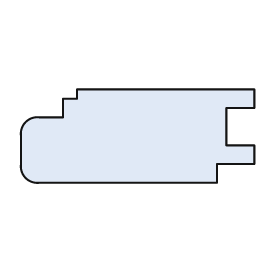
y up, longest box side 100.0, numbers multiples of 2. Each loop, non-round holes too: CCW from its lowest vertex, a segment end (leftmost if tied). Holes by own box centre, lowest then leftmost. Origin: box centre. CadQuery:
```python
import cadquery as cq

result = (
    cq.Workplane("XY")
    .moveTo(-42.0, -20.0)
    .lineTo(34.0, -20.0)
    .lineTo(34.0, -12.0)
    .lineTo(50.0, -12.0)
    .lineTo(50.0, -4.0)
    .lineTo(38.0, -4.0)
    .lineTo(38.0, 12.0)
    .lineTo(50.0, 12.0)
    .lineTo(50.0, 20.0)
    .lineTo(-26.0, 20.0)
    .lineTo(-26.0, 16.0)
    .lineTo(-32.0, 16.0)
    .lineTo(-32.0, 8.0)
    .lineTo(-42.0, 8.0)
    .threePointArc((-48.0, 6.0), (-50.0, 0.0))
    .lineTo(-50.0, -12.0)
    .threePointArc((-48.0, -18.0), (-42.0, -20.0))
    .close()
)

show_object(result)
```